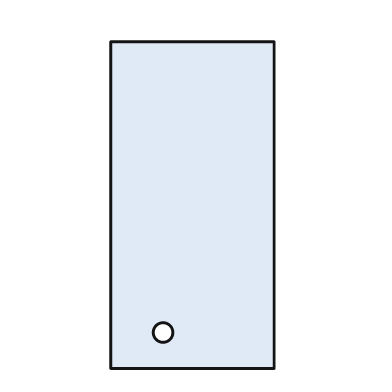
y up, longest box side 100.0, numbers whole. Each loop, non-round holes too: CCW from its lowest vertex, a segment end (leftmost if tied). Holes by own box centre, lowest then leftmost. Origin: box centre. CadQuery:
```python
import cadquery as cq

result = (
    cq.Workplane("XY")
    .moveTo(-25.0, -50.0)
    .lineTo(25.0, -50.0)
    .lineTo(25.0, 50.0)
    .lineTo(-25.0, 50.0)
    .close()
    .moveTo(-9.0, -39.0)
    .circle(3.0)
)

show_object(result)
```